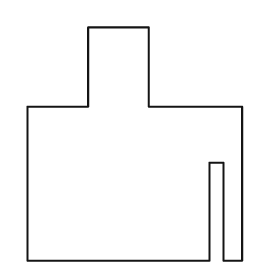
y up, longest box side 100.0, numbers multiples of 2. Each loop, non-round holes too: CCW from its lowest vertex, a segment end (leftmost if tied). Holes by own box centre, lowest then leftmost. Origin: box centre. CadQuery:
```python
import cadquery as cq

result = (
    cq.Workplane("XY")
    .moveTo(-46.0, -50.0)
    .lineTo(32.0, -50.0)
    .lineTo(32.0, -8.0)
    .lineTo(38.0, -8.0)
    .lineTo(38.0, -50.0)
    .lineTo(46.0, -50.0)
    .lineTo(46.0, 16.0)
    .lineTo(6.0, 16.0)
    .lineTo(6.0, 50.0)
    .lineTo(-20.0, 50.0)
    .lineTo(-20.0, 16.0)
    .lineTo(-46.0, 16.0)
    .close()
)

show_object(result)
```